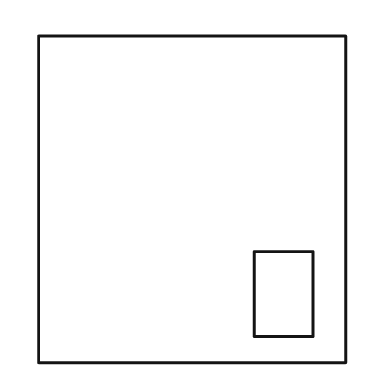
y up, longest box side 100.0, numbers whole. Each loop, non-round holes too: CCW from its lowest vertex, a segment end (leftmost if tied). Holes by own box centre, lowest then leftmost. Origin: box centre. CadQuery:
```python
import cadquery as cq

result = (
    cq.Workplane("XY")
    .moveTo(-47.0, -50.0)
    .lineTo(47.0, -50.0)
    .lineTo(47.0, 50.0)
    .lineTo(-47.0, 50.0)
    .close()
    .moveTo(19.0, -42.0)
    .lineTo(37.0, -42.0)
    .lineTo(37.0, -16.0)
    .lineTo(19.0, -16.0)
    .close()
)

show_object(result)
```